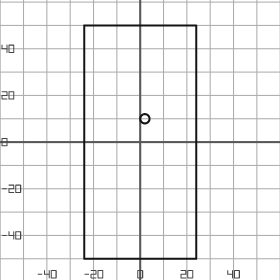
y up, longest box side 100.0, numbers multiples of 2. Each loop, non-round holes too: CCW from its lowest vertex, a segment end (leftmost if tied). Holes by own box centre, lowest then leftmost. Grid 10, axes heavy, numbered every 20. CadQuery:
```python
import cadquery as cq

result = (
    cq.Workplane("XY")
    .moveTo(-24.0, -50.0)
    .lineTo(24.0, -50.0)
    .lineTo(24.0, 50.0)
    .lineTo(-24.0, 50.0)
    .close()
    .moveTo(2.0, 10.0)
    .circle(2.0)
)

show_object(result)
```